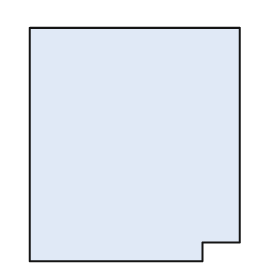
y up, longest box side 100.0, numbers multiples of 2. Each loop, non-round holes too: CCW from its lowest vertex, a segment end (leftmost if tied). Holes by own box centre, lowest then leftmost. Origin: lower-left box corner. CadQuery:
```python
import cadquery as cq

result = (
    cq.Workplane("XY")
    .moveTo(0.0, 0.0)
    .lineTo(74.0, 0.0)
    .lineTo(74.0, 8.0)
    .lineTo(90.0, 8.0)
    .lineTo(90.0, 100.0)
    .lineTo(0.0, 100.0)
    .close()
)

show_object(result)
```